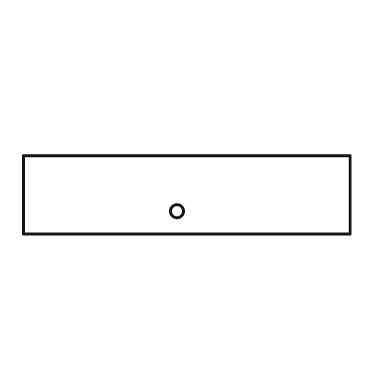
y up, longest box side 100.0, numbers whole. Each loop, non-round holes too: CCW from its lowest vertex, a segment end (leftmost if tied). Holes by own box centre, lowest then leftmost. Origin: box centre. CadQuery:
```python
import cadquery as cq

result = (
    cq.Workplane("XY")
    .moveTo(-50.0, -12.0)
    .lineTo(50.0, -12.0)
    .lineTo(50.0, 12.0)
    .lineTo(-50.0, 12.0)
    .close()
    .moveTo(-3.0, -5.0)
    .circle(2.0)
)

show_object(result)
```